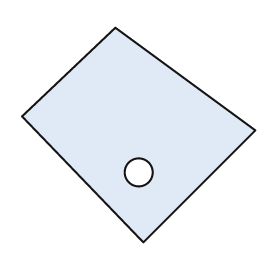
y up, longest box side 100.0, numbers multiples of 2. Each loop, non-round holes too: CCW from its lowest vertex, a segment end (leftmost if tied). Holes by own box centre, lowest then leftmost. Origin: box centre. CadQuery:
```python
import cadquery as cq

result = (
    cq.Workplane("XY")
    .moveTo(2.0, -46.0)
    .lineTo(50.0, 2.0)
    .lineTo(-10.0, 46.0)
    .lineTo(-50.0, 8.0)
    .close()
    .moveTo(0.0, -16.0)
    .circle(6.0)
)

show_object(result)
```